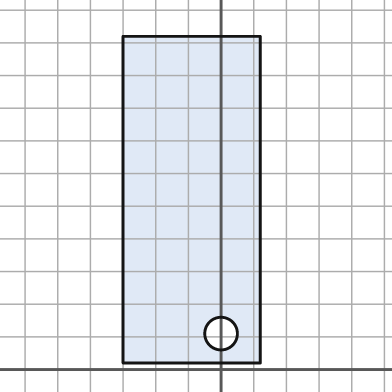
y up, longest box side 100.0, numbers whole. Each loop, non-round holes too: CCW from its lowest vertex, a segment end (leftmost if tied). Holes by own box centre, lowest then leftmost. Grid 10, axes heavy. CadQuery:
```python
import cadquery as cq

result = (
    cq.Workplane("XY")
    .moveTo(-30.0, 2.0)
    .lineTo(12.0, 2.0)
    .lineTo(12.0, 102.0)
    .lineTo(-30.0, 102.0)
    .close()
    .moveTo(0.0, 11.0)
    .circle(5.0)
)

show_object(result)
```